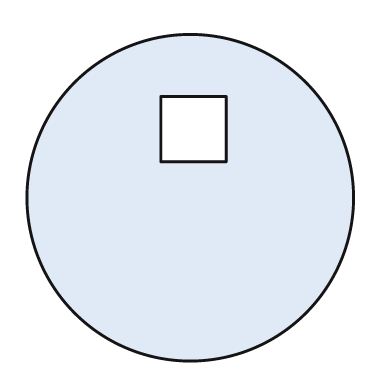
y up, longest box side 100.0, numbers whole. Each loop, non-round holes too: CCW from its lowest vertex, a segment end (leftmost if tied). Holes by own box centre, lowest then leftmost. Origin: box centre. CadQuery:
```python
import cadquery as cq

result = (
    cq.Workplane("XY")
    .moveTo(0.0, 0.0)
    .circle(50.0)
    .moveTo(-9.0, 11.0)
    .lineTo(11.0, 11.0)
    .lineTo(11.0, 31.0)
    .lineTo(-9.0, 31.0)
    .close()
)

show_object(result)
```